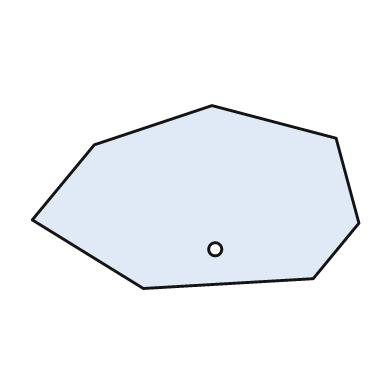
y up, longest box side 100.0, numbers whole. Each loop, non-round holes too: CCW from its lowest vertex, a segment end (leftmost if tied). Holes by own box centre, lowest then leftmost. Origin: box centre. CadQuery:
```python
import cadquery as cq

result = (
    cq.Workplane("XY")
    .moveTo(-16.0, -28.0)
    .lineTo(36.0, -25.0)
    .lineTo(50.0, -8.0)
    .lineTo(43.0, 18.0)
    .lineTo(5.0, 28.0)
    .lineTo(-31.0, 16.0)
    .lineTo(-50.0, -7.0)
    .close()
    .moveTo(6.0, -16.0)
    .circle(2.0)
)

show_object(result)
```